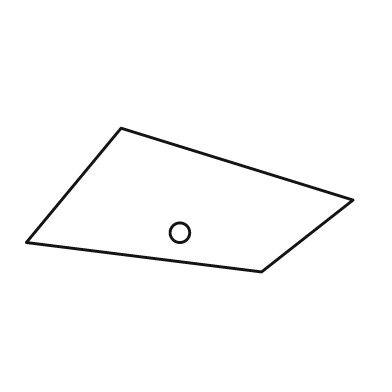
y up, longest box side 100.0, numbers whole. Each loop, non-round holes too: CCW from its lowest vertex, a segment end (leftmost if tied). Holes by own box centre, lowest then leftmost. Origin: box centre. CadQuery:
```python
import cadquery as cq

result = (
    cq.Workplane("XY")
    .moveTo(22.0, -22.0)
    .lineTo(50.0, 0.0)
    .lineTo(-21.0, 22.0)
    .lineTo(-50.0, -13.0)
    .close()
    .moveTo(-3.0, -10.0)
    .circle(3.0)
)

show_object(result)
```